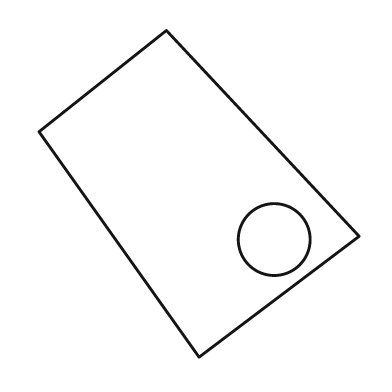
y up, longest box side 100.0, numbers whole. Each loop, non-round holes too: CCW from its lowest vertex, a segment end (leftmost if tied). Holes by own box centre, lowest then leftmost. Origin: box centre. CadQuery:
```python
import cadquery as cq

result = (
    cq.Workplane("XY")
    .moveTo(0.0, -50.0)
    .lineTo(49.0, -13.0)
    .lineTo(-10.0, 50.0)
    .lineTo(-49.0, 19.0)
    .close()
    .moveTo(23.0, -14.0)
    .circle(11.0)
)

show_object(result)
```